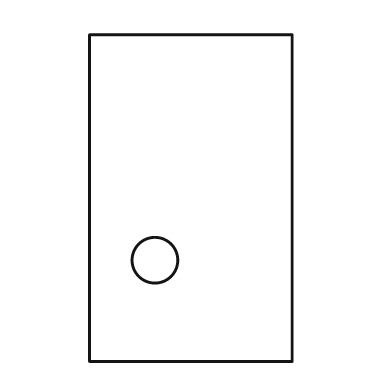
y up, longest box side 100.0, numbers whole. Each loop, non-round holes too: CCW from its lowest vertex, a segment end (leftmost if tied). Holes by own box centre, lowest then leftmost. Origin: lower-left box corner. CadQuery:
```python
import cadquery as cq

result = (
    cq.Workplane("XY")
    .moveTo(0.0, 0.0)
    .lineTo(62.0, 0.0)
    .lineTo(62.0, 100.0)
    .lineTo(0.0, 100.0)
    .close()
    .moveTo(20.0, 31.0)
    .circle(7.0)
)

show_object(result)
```